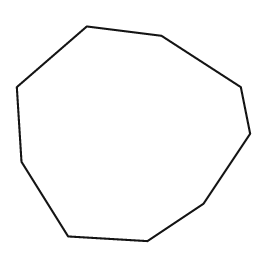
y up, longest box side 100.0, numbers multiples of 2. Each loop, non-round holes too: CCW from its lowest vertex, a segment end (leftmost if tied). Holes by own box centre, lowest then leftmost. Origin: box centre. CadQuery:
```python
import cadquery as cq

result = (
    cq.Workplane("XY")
    .moveTo(6.0, -46.0)
    .lineTo(30.0, -30.0)
    .lineTo(50.0, 0.0)
    .lineTo(46.0, 20.0)
    .lineTo(12.0, 42.0)
    .lineTo(-20.0, 46.0)
    .lineTo(-50.0, 20.0)
    .lineTo(-48.0, -12.0)
    .lineTo(-28.0, -44.0)
    .close()
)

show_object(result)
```